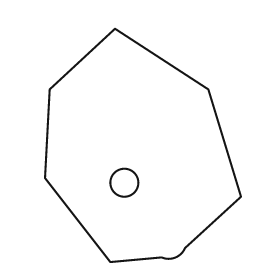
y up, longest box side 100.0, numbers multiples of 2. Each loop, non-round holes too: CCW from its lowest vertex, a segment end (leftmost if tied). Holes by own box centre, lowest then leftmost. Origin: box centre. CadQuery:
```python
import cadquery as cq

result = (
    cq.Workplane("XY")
    .moveTo(-14.0, -50.0)
    .lineTo(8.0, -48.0)
    .threePointArc((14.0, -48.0), (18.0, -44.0))
    .lineTo(42.0, -22.0)
    .lineTo(28.0, 24.0)
    .lineTo(-12.0, 50.0)
    .lineTo(-40.0, 24.0)
    .lineTo(-42.0, -14.0)
    .close()
    .moveTo(-8.0, -16.0)
    .circle(6.0)
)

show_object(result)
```